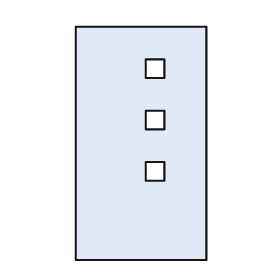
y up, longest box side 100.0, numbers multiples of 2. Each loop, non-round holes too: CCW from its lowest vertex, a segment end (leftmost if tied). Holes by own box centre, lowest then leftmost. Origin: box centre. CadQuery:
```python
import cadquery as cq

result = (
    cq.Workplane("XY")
    .moveTo(-28.0, -50.0)
    .lineTo(28.0, -50.0)
    .lineTo(28.0, 50.0)
    .lineTo(-28.0, 50.0)
    .close()
    .moveTo(2.0, -16.0)
    .lineTo(10.0, -16.0)
    .lineTo(10.0, -8.0)
    .lineTo(2.0, -8.0)
    .close()
    .moveTo(2.0, 6.0)
    .lineTo(10.0, 6.0)
    .lineTo(10.0, 14.0)
    .lineTo(2.0, 14.0)
    .close()
    .moveTo(2.0, 28.0)
    .lineTo(10.0, 28.0)
    .lineTo(10.0, 36.0)
    .lineTo(2.0, 36.0)
    .close()
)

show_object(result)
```